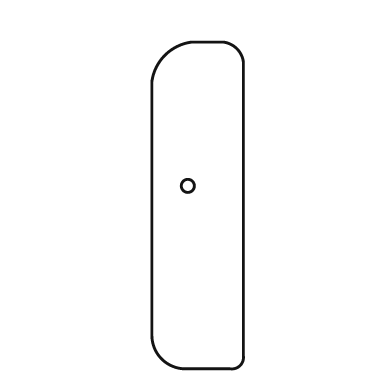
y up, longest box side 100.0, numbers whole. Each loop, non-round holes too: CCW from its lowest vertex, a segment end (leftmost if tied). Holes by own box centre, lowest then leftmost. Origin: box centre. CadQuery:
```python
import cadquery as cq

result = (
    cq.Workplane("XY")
    .moveTo(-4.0, -50.0)
    .lineTo(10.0, -50.0)
    .threePointArc((13.0, -49.0), (14.0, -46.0))
    .lineTo(14.0, 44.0)
    .threePointArc((12.0, 48.0), (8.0, 50.0))
    .lineTo(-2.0, 50.0)
    .threePointArc((-10.0, 46.0), (-14.0, 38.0))
    .lineTo(-14.0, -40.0)
    .threePointArc((-11.0, -47.0), (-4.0, -50.0))
    .close()
    .moveTo(-3.0, 6.0)
    .circle(2.0)
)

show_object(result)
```